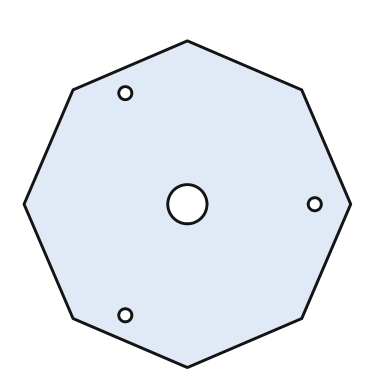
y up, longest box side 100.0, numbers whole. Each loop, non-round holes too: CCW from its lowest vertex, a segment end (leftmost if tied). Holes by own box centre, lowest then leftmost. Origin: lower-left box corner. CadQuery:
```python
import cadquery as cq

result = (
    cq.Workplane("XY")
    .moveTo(50.0, 0.0)
    .lineTo(85.0, 15.0)
    .lineTo(100.0, 50.0)
    .lineTo(85.0, 85.0)
    .lineTo(50.0, 100.0)
    .lineTo(15.0, 85.0)
    .lineTo(0.0, 50.0)
    .lineTo(15.0, 15.0)
    .close()
    .moveTo(31.0, 16.0)
    .circle(2.0)
    .moveTo(50.0, 50.0)
    .circle(6.0)
    .moveTo(89.0, 50.0)
    .circle(2.0)
    .moveTo(31.0, 84.0)
    .circle(2.0)
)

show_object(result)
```